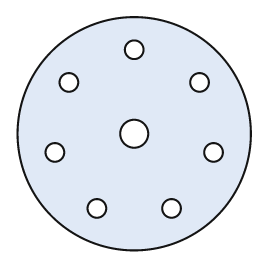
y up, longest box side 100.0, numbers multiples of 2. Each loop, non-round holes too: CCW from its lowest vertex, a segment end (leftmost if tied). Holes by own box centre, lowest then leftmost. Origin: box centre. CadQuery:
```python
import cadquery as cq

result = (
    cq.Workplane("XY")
    .moveTo(0.0, 0.0)
    .circle(50.0)
    .moveTo(-16.0, -32.0)
    .circle(4.0)
    .moveTo(16.0, -32.0)
    .circle(4.0)
    .moveTo(-34.0, -8.0)
    .circle(4.0)
    .moveTo(34.0, -8.0)
    .circle(4.0)
    .moveTo(0.0, 0.0)
    .circle(6.0)
    .moveTo(-28.0, 22.0)
    .circle(4.0)
    .moveTo(28.0, 22.0)
    .circle(4.0)
    .moveTo(0.0, 36.0)
    .circle(4.0)
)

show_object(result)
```